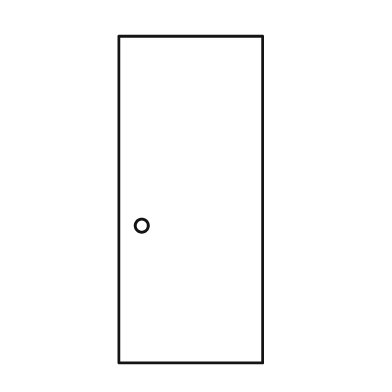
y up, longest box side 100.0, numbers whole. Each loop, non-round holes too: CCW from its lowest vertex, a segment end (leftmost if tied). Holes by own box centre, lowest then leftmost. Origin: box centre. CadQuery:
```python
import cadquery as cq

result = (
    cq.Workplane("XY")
    .moveTo(-22.0, -50.0)
    .lineTo(22.0, -50.0)
    .lineTo(22.0, 50.0)
    .lineTo(-22.0, 50.0)
    .close()
    .moveTo(-15.0, -8.0)
    .circle(2.0)
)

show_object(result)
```